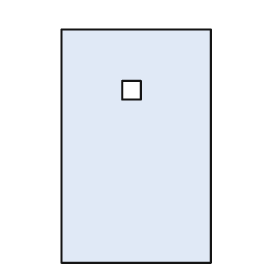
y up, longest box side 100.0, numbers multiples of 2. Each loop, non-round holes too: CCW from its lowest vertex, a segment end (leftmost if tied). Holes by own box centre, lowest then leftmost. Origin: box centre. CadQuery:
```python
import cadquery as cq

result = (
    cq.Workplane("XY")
    .moveTo(-32.0, -50.0)
    .lineTo(32.0, -50.0)
    .lineTo(32.0, 50.0)
    .lineTo(-32.0, 50.0)
    .close()
    .moveTo(-6.0, 20.0)
    .lineTo(2.0, 20.0)
    .lineTo(2.0, 28.0)
    .lineTo(-6.0, 28.0)
    .close()
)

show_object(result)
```